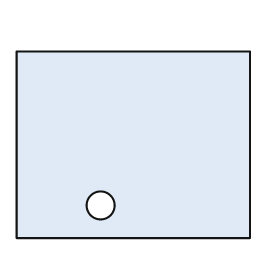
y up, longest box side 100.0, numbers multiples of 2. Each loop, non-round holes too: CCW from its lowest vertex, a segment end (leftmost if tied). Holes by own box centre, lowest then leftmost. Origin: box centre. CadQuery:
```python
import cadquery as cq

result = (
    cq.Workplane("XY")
    .moveTo(-50.0, -40.0)
    .lineTo(50.0, -40.0)
    .lineTo(50.0, 40.0)
    .lineTo(-50.0, 40.0)
    .close()
    .moveTo(-14.0, -26.0)
    .circle(6.0)
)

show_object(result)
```